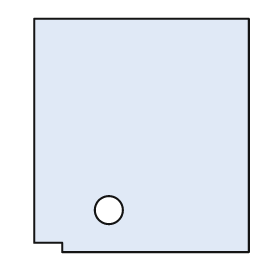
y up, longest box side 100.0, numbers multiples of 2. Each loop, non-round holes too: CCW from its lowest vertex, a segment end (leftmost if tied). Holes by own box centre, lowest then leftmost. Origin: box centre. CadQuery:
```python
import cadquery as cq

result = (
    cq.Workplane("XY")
    .moveTo(-34.0, -50.0)
    .lineTo(46.0, -50.0)
    .lineTo(46.0, 50.0)
    .lineTo(-46.0, 50.0)
    .lineTo(-46.0, -46.0)
    .lineTo(-34.0, -46.0)
    .close()
    .moveTo(-14.0, -32.0)
    .circle(6.0)
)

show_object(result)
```